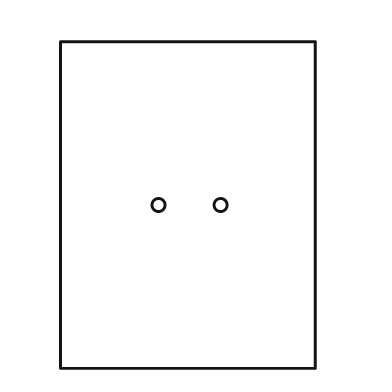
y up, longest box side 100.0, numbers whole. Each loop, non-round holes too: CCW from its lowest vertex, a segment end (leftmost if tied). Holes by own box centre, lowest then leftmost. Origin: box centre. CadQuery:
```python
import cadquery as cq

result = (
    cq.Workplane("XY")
    .moveTo(-39.0, -50.0)
    .lineTo(39.0, -50.0)
    .lineTo(39.0, 50.0)
    .lineTo(-39.0, 50.0)
    .close()
    .moveTo(-9.0, 0.0)
    .circle(2.0)
    .moveTo(10.0, 0.0)
    .circle(2.0)
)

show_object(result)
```